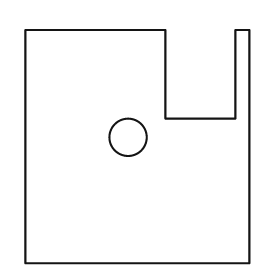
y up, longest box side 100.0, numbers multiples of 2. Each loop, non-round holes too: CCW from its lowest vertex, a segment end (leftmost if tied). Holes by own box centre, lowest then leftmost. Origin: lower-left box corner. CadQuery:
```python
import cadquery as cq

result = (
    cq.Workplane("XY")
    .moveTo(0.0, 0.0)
    .lineTo(96.0, 0.0)
    .lineTo(96.0, 100.0)
    .lineTo(90.0, 100.0)
    .lineTo(90.0, 62.0)
    .lineTo(60.0, 62.0)
    .lineTo(60.0, 100.0)
    .lineTo(0.0, 100.0)
    .close()
    .moveTo(44.0, 54.0)
    .circle(8.0)
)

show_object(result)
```